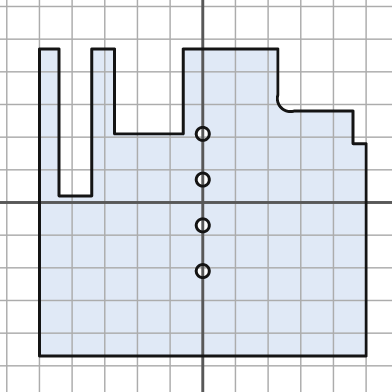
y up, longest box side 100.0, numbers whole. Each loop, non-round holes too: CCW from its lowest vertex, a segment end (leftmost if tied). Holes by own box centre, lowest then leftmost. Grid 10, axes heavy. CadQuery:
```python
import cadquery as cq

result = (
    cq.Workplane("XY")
    .moveTo(-50.0, -47.0)
    .lineTo(50.0, -47.0)
    .lineTo(50.0, 18.0)
    .lineTo(46.0, 18.0)
    .lineTo(46.0, 28.0)
    .lineTo(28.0, 28.0)
    .threePointArc((24.0, 29.0), (23.0, 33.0))
    .lineTo(23.0, 47.0)
    .lineTo(-6.0, 47.0)
    .lineTo(-6.0, 21.0)
    .lineTo(-27.0, 21.0)
    .lineTo(-27.0, 47.0)
    .lineTo(-34.0, 47.0)
    .lineTo(-34.0, 2.0)
    .lineTo(-44.0, 2.0)
    .lineTo(-44.0, 47.0)
    .lineTo(-50.0, 47.0)
    .close()
    .moveTo(0.0, -21.0)
    .circle(2.0)
    .moveTo(0.0, -7.0)
    .circle(2.0)
    .moveTo(0.0, 7.0)
    .circle(2.0)
    .moveTo(0.0, 21.0)
    .circle(2.0)
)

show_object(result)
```